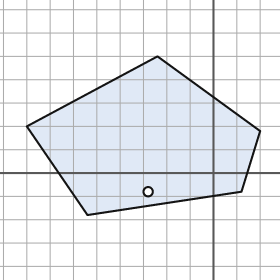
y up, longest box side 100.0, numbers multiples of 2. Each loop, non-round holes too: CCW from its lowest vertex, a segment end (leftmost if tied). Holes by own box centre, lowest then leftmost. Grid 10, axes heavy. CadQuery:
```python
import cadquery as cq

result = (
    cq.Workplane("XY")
    .moveTo(-54.0, -18.0)
    .lineTo(12.0, -8.0)
    .lineTo(20.0, 18.0)
    .lineTo(-24.0, 50.0)
    .lineTo(-80.0, 20.0)
    .close()
    .moveTo(-28.0, -8.0)
    .circle(2.0)
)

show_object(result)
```